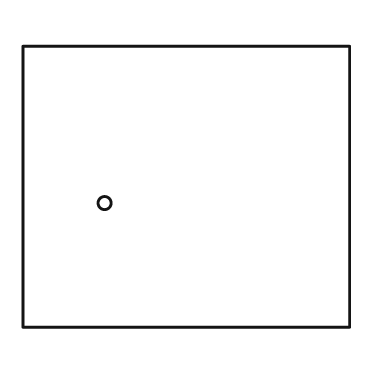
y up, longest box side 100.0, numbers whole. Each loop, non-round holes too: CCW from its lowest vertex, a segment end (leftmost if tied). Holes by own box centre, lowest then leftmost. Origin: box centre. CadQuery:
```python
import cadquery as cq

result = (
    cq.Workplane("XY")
    .moveTo(-50.0, -43.0)
    .lineTo(50.0, -43.0)
    .lineTo(50.0, 43.0)
    .lineTo(-50.0, 43.0)
    .close()
    .moveTo(-25.0, -5.0)
    .circle(2.0)
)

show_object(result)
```